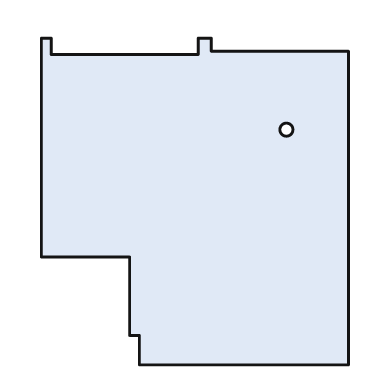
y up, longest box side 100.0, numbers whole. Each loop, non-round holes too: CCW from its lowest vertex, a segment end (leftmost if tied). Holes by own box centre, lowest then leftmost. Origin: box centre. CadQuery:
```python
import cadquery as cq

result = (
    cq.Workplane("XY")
    .moveTo(-17.0, -50.0)
    .lineTo(47.0, -50.0)
    .lineTo(47.0, 46.0)
    .lineTo(5.0, 46.0)
    .lineTo(5.0, 50.0)
    .lineTo(1.0, 50.0)
    .lineTo(1.0, 45.0)
    .lineTo(-44.0, 45.0)
    .lineTo(-44.0, 50.0)
    .lineTo(-47.0, 50.0)
    .lineTo(-47.0, -17.0)
    .lineTo(-20.0, -17.0)
    .lineTo(-20.0, -41.0)
    .lineTo(-17.0, -41.0)
    .close()
    .moveTo(28.0, 22.0)
    .circle(2.0)
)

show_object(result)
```